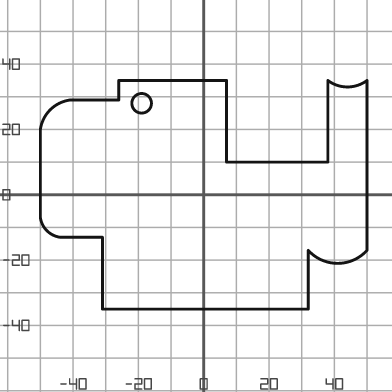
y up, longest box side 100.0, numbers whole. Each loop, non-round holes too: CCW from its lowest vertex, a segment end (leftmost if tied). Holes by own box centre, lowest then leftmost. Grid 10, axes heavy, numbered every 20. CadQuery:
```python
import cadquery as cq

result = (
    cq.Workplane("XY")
    .moveTo(-31.0, -35.0)
    .lineTo(32.0, -35.0)
    .lineTo(32.0, -17.0)
    .threePointArc((41.0, -21.0), (50.0, -17.0))
    .lineTo(50.0, 35.0)
    .threePointArc((44.0, 33.0), (38.0, 35.0))
    .lineTo(38.0, 10.0)
    .lineTo(7.0, 10.0)
    .lineTo(7.0, 35.0)
    .lineTo(-26.0, 35.0)
    .lineTo(-26.0, 29.0)
    .lineTo(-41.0, 29.0)
    .threePointArc((-47.0, 26.0), (-50.0, 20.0))
    .lineTo(-50.0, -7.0)
    .threePointArc((-48.0, -11.0), (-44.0, -13.0))
    .lineTo(-31.0, -13.0)
    .close()
    .moveTo(-19.0, 28.0)
    .circle(3.0)
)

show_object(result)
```